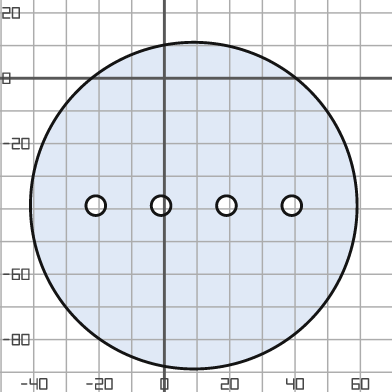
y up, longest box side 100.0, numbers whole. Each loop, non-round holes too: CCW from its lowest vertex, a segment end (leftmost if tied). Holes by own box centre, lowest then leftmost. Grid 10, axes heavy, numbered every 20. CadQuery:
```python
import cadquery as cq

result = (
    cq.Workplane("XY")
    .moveTo(9.0, -39.0)
    .circle(50.0)
    .moveTo(-21.0, -39.0)
    .circle(3.0)
    .moveTo(-1.0, -39.0)
    .circle(3.0)
    .moveTo(19.0, -39.0)
    .circle(3.0)
    .moveTo(39.0, -39.0)
    .circle(3.0)
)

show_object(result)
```